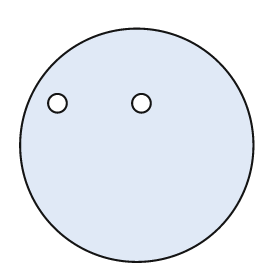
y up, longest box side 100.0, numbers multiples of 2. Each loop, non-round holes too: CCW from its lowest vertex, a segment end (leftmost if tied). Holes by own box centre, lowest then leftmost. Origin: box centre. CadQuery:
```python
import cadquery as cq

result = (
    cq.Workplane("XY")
    .moveTo(0.0, 0.0)
    .circle(50.0)
    .moveTo(-34.0, 18.0)
    .circle(4.0)
    .moveTo(2.0, 18.0)
    .circle(4.0)
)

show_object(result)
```